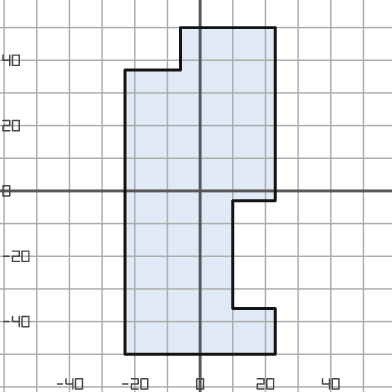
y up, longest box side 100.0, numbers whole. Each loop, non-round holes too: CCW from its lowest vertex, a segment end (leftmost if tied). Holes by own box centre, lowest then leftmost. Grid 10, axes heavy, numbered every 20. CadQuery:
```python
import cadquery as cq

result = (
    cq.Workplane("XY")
    .moveTo(-23.0, -50.0)
    .lineTo(23.0, -50.0)
    .lineTo(23.0, -36.0)
    .lineTo(10.0, -36.0)
    .lineTo(10.0, -3.0)
    .lineTo(23.0, -3.0)
    .lineTo(23.0, 50.0)
    .lineTo(-6.0, 50.0)
    .lineTo(-6.0, 37.0)
    .lineTo(-23.0, 37.0)
    .close()
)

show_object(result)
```